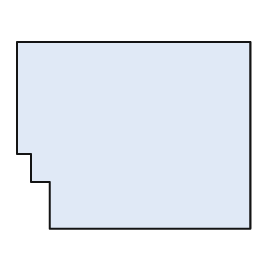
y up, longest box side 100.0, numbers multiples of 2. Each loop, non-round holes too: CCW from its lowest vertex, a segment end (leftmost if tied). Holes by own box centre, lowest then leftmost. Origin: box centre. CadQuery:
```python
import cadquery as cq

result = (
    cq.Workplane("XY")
    .moveTo(-36.0, -40.0)
    .lineTo(50.0, -40.0)
    .lineTo(50.0, 40.0)
    .lineTo(-50.0, 40.0)
    .lineTo(-50.0, -8.0)
    .lineTo(-44.0, -8.0)
    .lineTo(-44.0, -20.0)
    .lineTo(-36.0, -20.0)
    .close()
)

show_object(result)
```